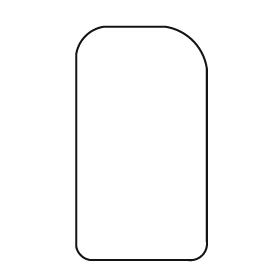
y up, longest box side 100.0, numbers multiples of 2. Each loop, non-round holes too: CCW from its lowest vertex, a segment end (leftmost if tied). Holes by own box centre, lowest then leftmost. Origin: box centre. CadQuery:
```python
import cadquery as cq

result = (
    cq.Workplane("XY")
    .moveTo(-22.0, -50.0)
    .lineTo(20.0, -50.0)
    .threePointArc((26.0, -48.0), (28.0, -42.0))
    .lineTo(28.0, 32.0)
    .threePointArc((22.0, 44.0), (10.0, 50.0))
    .lineTo(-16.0, 50.0)
    .threePointArc((-24.0, 46.0), (-28.0, 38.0))
    .lineTo(-28.0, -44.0)
    .threePointArc((-26.0, -48.0), (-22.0, -50.0))
    .close()
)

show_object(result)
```